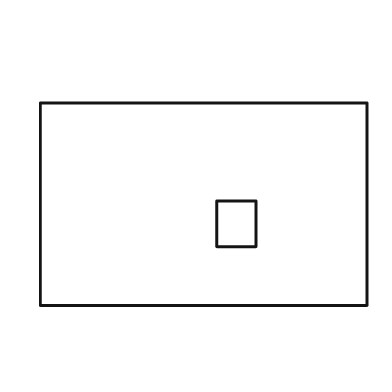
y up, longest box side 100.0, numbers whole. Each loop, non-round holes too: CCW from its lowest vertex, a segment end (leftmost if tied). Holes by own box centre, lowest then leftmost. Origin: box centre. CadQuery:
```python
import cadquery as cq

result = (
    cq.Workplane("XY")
    .moveTo(-50.0, -31.0)
    .lineTo(50.0, -31.0)
    .lineTo(50.0, 31.0)
    .lineTo(-50.0, 31.0)
    .close()
    .moveTo(4.0, -13.0)
    .lineTo(16.0, -13.0)
    .lineTo(16.0, 1.0)
    .lineTo(4.0, 1.0)
    .close()
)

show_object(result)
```